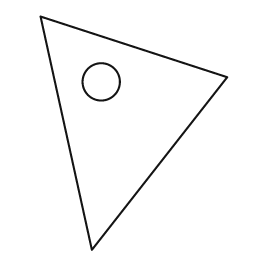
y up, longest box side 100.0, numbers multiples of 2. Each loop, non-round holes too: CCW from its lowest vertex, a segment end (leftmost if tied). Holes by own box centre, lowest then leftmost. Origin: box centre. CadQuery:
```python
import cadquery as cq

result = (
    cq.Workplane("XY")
    .moveTo(-18.0, -50.0)
    .lineTo(40.0, 24.0)
    .lineTo(-40.0, 50.0)
    .close()
    .moveTo(-14.0, 22.0)
    .circle(8.0)
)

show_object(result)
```